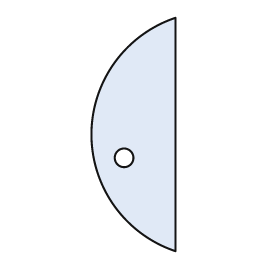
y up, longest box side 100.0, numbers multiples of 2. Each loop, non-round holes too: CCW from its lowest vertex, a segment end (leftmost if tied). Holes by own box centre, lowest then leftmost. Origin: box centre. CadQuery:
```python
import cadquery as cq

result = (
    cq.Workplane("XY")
    .moveTo(18.0, -50.0)
    .lineTo(18.0, 50.0)
    .threePointArc((-18.0, 0.0), (18.0, -50.0))
    .close()
    .moveTo(-4.0, -10.0)
    .circle(4.0)
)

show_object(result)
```